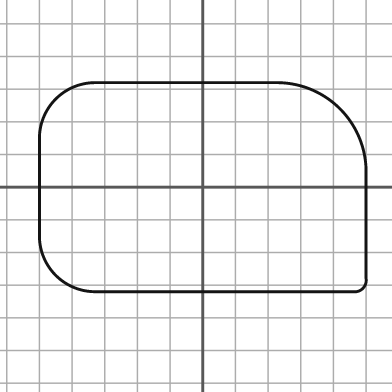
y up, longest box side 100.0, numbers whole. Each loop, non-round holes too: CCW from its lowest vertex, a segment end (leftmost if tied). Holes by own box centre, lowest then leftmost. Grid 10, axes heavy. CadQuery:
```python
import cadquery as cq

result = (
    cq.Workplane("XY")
    .moveTo(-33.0, -32.0)
    .lineTo(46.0, -32.0)
    .threePointArc((49.0, -31.0), (50.0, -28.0))
    .lineTo(50.0, 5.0)
    .threePointArc((42.0, 24.0), (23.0, 32.0))
    .lineTo(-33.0, 32.0)
    .threePointArc((-45.0, 27.0), (-50.0, 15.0))
    .lineTo(-50.0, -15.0)
    .threePointArc((-45.0, -27.0), (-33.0, -32.0))
    .close()
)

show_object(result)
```